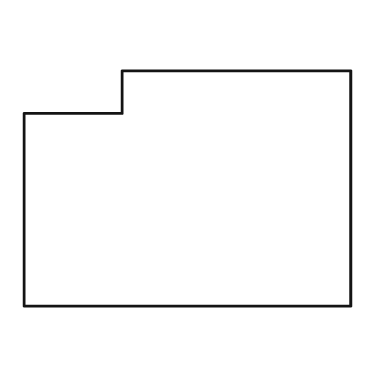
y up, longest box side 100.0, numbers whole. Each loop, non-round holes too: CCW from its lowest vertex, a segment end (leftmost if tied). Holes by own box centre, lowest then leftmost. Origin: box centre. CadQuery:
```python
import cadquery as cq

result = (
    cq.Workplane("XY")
    .moveTo(-50.0, -36.0)
    .lineTo(50.0, -36.0)
    .lineTo(50.0, 36.0)
    .lineTo(-20.0, 36.0)
    .lineTo(-20.0, 23.0)
    .lineTo(-50.0, 23.0)
    .close()
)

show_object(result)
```